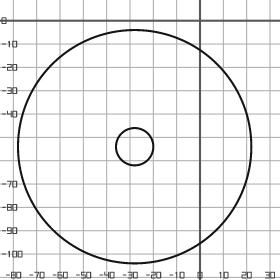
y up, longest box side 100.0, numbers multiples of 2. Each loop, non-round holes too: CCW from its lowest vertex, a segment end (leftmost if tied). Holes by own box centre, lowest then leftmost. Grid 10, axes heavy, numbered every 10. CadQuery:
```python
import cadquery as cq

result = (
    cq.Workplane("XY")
    .moveTo(-28.0, -54.0)
    .circle(50.0)
    .moveTo(-28.0, -54.0)
    .circle(8.0)
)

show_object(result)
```